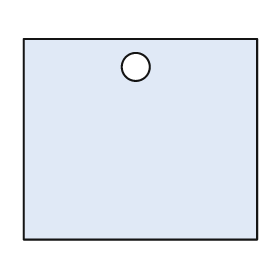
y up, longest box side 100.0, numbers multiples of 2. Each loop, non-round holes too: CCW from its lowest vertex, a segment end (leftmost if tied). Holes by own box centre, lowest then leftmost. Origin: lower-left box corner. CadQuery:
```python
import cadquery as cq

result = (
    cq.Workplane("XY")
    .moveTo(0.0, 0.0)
    .lineTo(100.0, 0.0)
    .lineTo(100.0, 86.0)
    .lineTo(0.0, 86.0)
    .close()
    .moveTo(48.0, 74.0)
    .circle(6.0)
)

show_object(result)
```